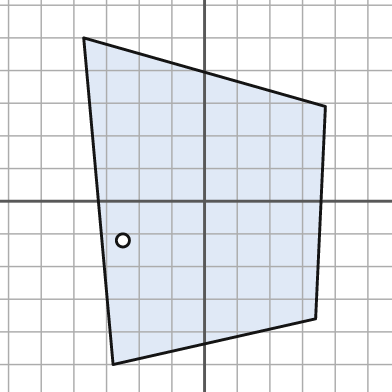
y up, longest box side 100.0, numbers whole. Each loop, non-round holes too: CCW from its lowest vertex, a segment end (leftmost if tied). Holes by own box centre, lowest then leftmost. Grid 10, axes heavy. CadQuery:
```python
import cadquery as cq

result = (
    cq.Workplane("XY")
    .moveTo(-28.0, -50.0)
    .lineTo(34.0, -36.0)
    .lineTo(37.0, 29.0)
    .lineTo(-37.0, 50.0)
    .close()
    .moveTo(-25.0, -12.0)
    .circle(2.0)
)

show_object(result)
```